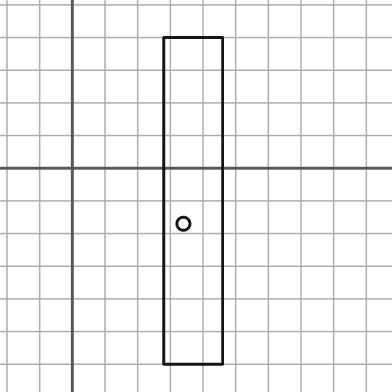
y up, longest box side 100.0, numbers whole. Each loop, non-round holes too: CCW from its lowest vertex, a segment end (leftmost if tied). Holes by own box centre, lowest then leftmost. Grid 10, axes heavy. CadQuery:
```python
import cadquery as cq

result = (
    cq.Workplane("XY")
    .moveTo(28.0, -60.0)
    .lineTo(46.0, -60.0)
    .lineTo(46.0, 40.0)
    .lineTo(28.0, 40.0)
    .close()
    .moveTo(34.0, -17.0)
    .circle(2.0)
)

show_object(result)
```